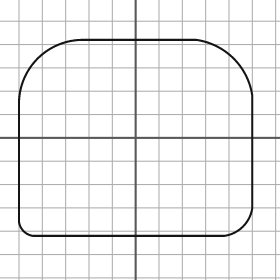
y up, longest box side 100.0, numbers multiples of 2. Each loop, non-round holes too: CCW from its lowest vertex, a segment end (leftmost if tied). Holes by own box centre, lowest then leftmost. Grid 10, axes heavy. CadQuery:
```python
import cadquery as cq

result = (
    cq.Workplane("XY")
    .moveTo(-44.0, -42.0)
    .lineTo(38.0, -42.0)
    .threePointArc((46.0, -38.0), (50.0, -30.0))
    .lineTo(50.0, 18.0)
    .threePointArc((42.0, 34.0), (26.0, 42.0))
    .lineTo(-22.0, 42.0)
    .threePointArc((-42.0, 34.0), (-50.0, 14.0))
    .lineTo(-50.0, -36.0)
    .threePointArc((-48.0, -40.0), (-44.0, -42.0))
    .close()
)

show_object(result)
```